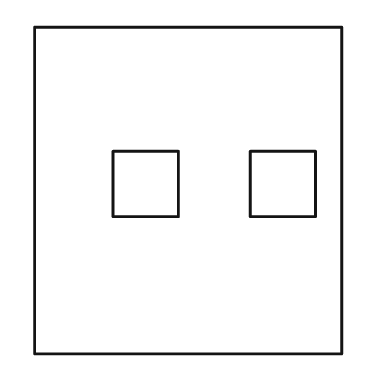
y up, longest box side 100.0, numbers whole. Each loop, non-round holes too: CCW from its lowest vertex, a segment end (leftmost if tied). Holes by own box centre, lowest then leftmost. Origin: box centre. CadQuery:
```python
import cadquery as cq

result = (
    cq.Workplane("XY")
    .moveTo(-47.0, -50.0)
    .lineTo(47.0, -50.0)
    .lineTo(47.0, 50.0)
    .lineTo(-47.0, 50.0)
    .close()
    .moveTo(-23.0, -8.0)
    .lineTo(-3.0, -8.0)
    .lineTo(-3.0, 12.0)
    .lineTo(-23.0, 12.0)
    .close()
    .moveTo(19.0, -8.0)
    .lineTo(39.0, -8.0)
    .lineTo(39.0, 12.0)
    .lineTo(19.0, 12.0)
    .close()
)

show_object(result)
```